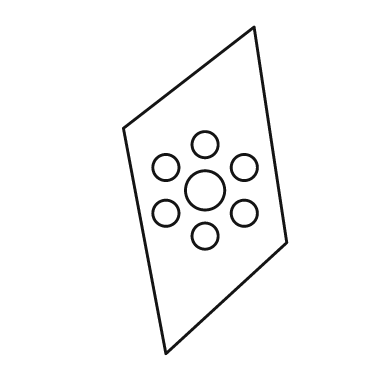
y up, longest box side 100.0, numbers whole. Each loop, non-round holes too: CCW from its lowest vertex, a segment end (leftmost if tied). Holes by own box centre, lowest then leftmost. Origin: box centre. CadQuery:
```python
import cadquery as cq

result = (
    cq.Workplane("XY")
    .moveTo(-12.0, -50.0)
    .lineTo(25.0, -16.0)
    .lineTo(15.0, 50.0)
    .lineTo(-25.0, 19.0)
    .close()
    .moveTo(0.0, -14.0)
    .circle(4.0)
    .moveTo(-12.0, -7.0)
    .circle(4.0)
    .moveTo(12.0, -7.0)
    .circle(4.0)
    .moveTo(0.0, 0.0)
    .circle(6.0)
    .moveTo(-12.0, 7.0)
    .circle(4.0)
    .moveTo(12.0, 7.0)
    .circle(4.0)
    .moveTo(0.0, 14.0)
    .circle(4.0)
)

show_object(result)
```